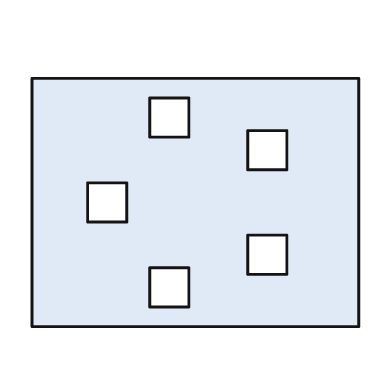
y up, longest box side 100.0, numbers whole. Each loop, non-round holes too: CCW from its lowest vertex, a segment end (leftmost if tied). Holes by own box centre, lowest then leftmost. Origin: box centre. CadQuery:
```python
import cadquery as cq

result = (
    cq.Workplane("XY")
    .moveTo(-50.0, -38.0)
    .lineTo(50.0, -38.0)
    .lineTo(50.0, 38.0)
    .lineTo(-50.0, 38.0)
    .close()
    .moveTo(-14.0, -32.0)
    .lineTo(-2.0, -32.0)
    .lineTo(-2.0, -20.0)
    .lineTo(-14.0, -20.0)
    .close()
    .moveTo(16.0, -22.0)
    .lineTo(28.0, -22.0)
    .lineTo(28.0, -10.0)
    .lineTo(16.0, -10.0)
    .close()
    .moveTo(-33.0, -6.0)
    .lineTo(-21.0, -6.0)
    .lineTo(-21.0, 6.0)
    .lineTo(-33.0, 6.0)
    .close()
    .moveTo(16.0, 10.0)
    .lineTo(28.0, 10.0)
    .lineTo(28.0, 22.0)
    .lineTo(16.0, 22.0)
    .close()
    .moveTo(-14.0, 20.0)
    .lineTo(-2.0, 20.0)
    .lineTo(-2.0, 32.0)
    .lineTo(-14.0, 32.0)
    .close()
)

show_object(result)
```